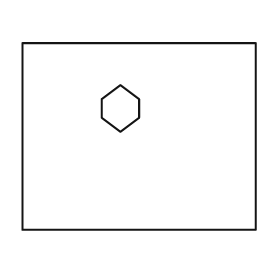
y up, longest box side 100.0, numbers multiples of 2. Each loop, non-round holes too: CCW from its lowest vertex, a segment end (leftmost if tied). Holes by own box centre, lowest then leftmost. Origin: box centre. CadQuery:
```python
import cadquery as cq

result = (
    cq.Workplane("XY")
    .moveTo(-50.0, -40.0)
    .lineTo(50.0, -40.0)
    .lineTo(50.0, 40.0)
    .lineTo(-50.0, 40.0)
    .close()
    .moveTo(-8.0, 2.0)
    .lineTo(0.0, 8.0)
    .lineTo(0.0, 16.0)
    .lineTo(-8.0, 22.0)
    .lineTo(-16.0, 16.0)
    .lineTo(-16.0, 8.0)
    .close()
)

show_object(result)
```